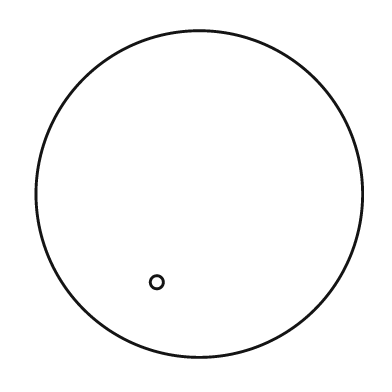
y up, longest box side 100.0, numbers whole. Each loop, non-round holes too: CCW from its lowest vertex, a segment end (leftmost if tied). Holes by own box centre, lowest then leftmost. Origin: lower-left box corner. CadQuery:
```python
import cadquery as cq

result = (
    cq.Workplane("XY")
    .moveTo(50.0, 50.0)
    .circle(50.0)
    .moveTo(37.0, 23.0)
    .circle(2.0)
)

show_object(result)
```